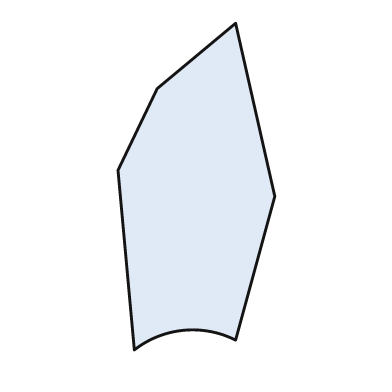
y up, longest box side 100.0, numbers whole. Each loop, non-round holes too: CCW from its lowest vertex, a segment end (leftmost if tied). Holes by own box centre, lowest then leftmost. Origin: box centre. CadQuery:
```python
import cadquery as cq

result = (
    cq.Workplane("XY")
    .moveTo(-19.0, -50.0)
    .threePointArc((-4.0, -44.0), (12.0, -47.0))
    .lineTo(24.0, -3.0)
    .lineTo(12.0, 50.0)
    .lineTo(-12.0, 30.0)
    .lineTo(-24.0, 5.0)
    .close()
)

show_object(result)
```